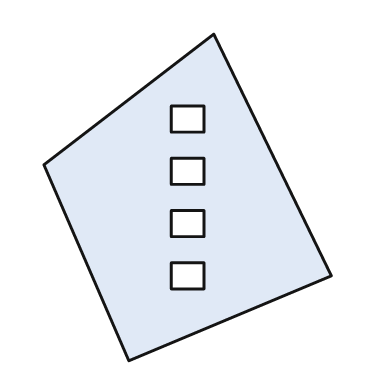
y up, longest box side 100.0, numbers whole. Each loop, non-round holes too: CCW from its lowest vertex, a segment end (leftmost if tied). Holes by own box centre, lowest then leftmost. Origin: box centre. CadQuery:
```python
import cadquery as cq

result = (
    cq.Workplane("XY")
    .moveTo(-18.0, -50.0)
    .lineTo(44.0, -24.0)
    .lineTo(8.0, 50.0)
    .lineTo(-44.0, 10.0)
    .close()
    .moveTo(-5.0, -28.0)
    .lineTo(5.0, -28.0)
    .lineTo(5.0, -20.0)
    .lineTo(-5.0, -20.0)
    .close()
    .moveTo(-5.0, -12.0)
    .lineTo(5.0, -12.0)
    .lineTo(5.0, -4.0)
    .lineTo(-5.0, -4.0)
    .close()
    .moveTo(-5.0, 4.0)
    .lineTo(5.0, 4.0)
    .lineTo(5.0, 12.0)
    .lineTo(-5.0, 12.0)
    .close()
    .moveTo(-5.0, 20.0)
    .lineTo(5.0, 20.0)
    .lineTo(5.0, 28.0)
    .lineTo(-5.0, 28.0)
    .close()
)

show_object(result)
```